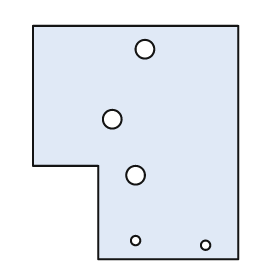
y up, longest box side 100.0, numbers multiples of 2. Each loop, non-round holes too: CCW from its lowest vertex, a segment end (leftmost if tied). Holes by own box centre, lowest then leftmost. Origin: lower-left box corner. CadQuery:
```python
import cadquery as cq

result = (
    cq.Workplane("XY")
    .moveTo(28.0, 0.0)
    .lineTo(88.0, 0.0)
    .lineTo(88.0, 100.0)
    .lineTo(0.0, 100.0)
    .lineTo(0.0, 40.0)
    .lineTo(28.0, 40.0)
    .close()
    .moveTo(74.0, 6.0)
    .circle(2.0)
    .moveTo(44.0, 8.0)
    .circle(2.0)
    .moveTo(44.0, 36.0)
    .circle(4.0)
    .moveTo(34.0, 60.0)
    .circle(4.0)
    .moveTo(48.0, 90.0)
    .circle(4.0)
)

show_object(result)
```